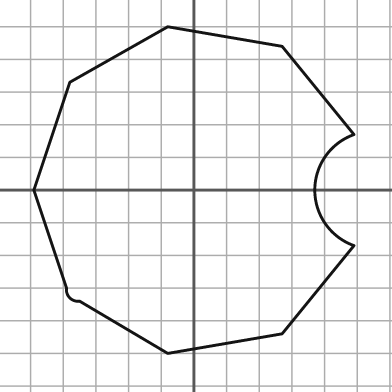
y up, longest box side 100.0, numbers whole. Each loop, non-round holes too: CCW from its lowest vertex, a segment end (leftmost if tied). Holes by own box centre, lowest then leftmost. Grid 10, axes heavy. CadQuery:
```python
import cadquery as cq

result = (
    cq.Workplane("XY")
    .moveTo(-8.0, -50.0)
    .lineTo(27.0, -44.0)
    .lineTo(49.0, -17.0)
    .threePointArc((37.0, 0.0), (49.0, 17.0))
    .lineTo(27.0, 44.0)
    .lineTo(-8.0, 50.0)
    .lineTo(-38.0, 33.0)
    .lineTo(-49.0, 0.0)
    .lineTo(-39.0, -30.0)
    .threePointArc((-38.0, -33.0), (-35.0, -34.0))
    .close()
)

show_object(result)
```